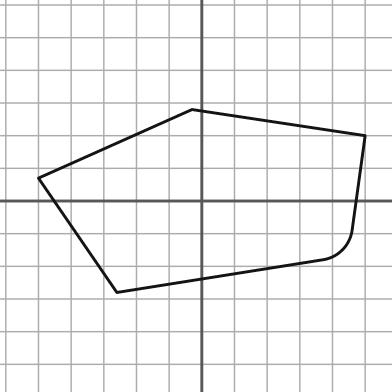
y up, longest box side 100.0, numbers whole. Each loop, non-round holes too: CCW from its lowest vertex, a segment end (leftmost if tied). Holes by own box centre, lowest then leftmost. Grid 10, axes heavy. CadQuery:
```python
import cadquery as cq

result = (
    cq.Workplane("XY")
    .moveTo(-26.0, -28.0)
    .lineTo(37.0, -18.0)
    .threePointArc((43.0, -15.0), (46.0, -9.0))
    .lineTo(50.0, 20.0)
    .lineTo(-3.0, 28.0)
    .lineTo(-50.0, 7.0)
    .close()
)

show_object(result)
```